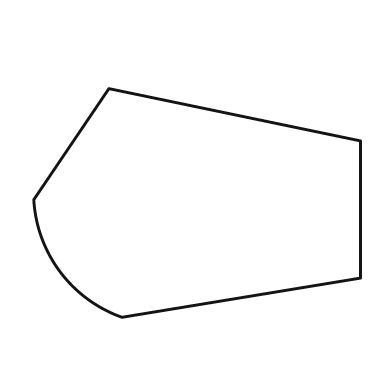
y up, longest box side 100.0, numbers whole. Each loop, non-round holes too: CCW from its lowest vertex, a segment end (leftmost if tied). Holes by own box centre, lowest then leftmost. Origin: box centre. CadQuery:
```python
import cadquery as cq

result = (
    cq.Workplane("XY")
    .moveTo(-23.0, -35.0)
    .lineTo(50.0, -23.0)
    .lineTo(50.0, 19.0)
    .lineTo(-27.0, 35.0)
    .lineTo(-50.0, 1.0)
    .threePointArc((-42.0, -21.0), (-23.0, -35.0))
    .close()
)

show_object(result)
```